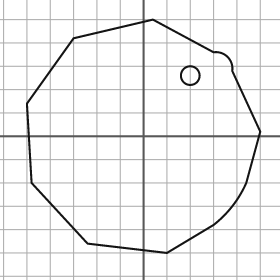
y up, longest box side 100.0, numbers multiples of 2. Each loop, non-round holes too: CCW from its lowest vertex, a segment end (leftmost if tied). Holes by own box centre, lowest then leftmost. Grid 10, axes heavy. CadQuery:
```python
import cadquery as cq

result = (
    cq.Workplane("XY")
    .moveTo(10.0, -50.0)
    .lineTo(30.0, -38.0)
    .threePointArc((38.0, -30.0), (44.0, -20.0))
    .lineTo(50.0, 2.0)
    .lineTo(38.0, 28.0)
    .threePointArc((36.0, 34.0), (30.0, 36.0))
    .lineTo(4.0, 50.0)
    .lineTo(-30.0, 42.0)
    .lineTo(-50.0, 14.0)
    .lineTo(-48.0, -20.0)
    .lineTo(-24.0, -46.0)
    .close()
    .moveTo(20.0, 26.0)
    .circle(4.0)
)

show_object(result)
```